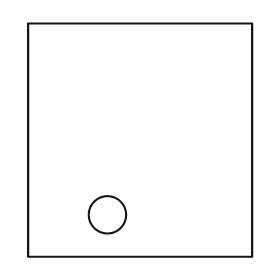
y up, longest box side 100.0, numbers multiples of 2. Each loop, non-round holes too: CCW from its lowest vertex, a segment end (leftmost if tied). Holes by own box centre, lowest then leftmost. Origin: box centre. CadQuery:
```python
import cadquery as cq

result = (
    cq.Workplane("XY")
    .moveTo(-48.0, -50.0)
    .lineTo(48.0, -50.0)
    .lineTo(48.0, 50.0)
    .lineTo(-48.0, 50.0)
    .close()
    .moveTo(-14.0, -32.0)
    .circle(8.0)
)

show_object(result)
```